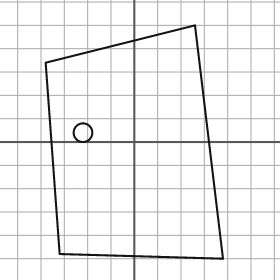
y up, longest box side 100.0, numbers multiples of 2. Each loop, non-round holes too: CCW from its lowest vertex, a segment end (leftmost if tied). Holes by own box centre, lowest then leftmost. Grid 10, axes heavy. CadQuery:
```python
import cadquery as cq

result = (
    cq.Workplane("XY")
    .moveTo(38.0, -50.0)
    .lineTo(26.0, 50.0)
    .lineTo(-38.0, 34.0)
    .lineTo(-32.0, -48.0)
    .close()
    .moveTo(-22.0, 4.0)
    .circle(4.0)
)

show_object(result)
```